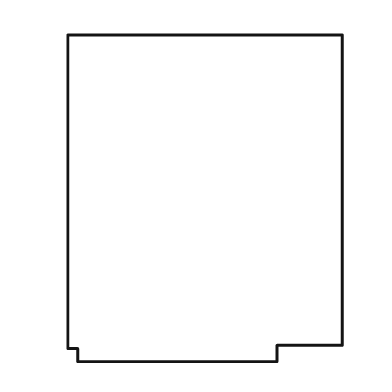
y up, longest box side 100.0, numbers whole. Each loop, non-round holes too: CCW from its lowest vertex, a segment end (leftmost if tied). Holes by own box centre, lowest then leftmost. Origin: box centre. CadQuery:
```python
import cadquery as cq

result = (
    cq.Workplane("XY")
    .moveTo(-39.0, -50.0)
    .lineTo(22.0, -50.0)
    .lineTo(22.0, -45.0)
    .lineTo(42.0, -45.0)
    .lineTo(42.0, 50.0)
    .lineTo(-42.0, 50.0)
    .lineTo(-42.0, -46.0)
    .lineTo(-39.0, -46.0)
    .close()
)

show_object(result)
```